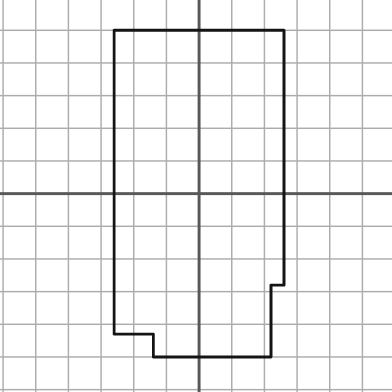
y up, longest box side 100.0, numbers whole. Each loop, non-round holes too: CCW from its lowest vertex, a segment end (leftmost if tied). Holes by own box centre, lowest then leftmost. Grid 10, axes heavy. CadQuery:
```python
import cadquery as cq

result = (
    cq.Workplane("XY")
    .moveTo(-14.0, -50.0)
    .lineTo(22.0, -50.0)
    .lineTo(22.0, -28.0)
    .lineTo(26.0, -28.0)
    .lineTo(26.0, 50.0)
    .lineTo(-26.0, 50.0)
    .lineTo(-26.0, -43.0)
    .lineTo(-14.0, -43.0)
    .close()
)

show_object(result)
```